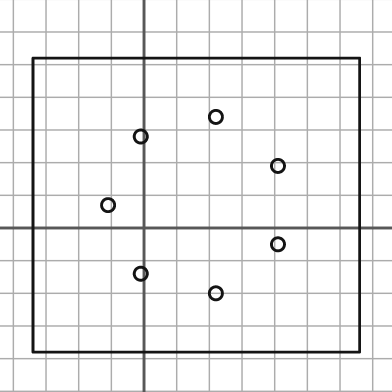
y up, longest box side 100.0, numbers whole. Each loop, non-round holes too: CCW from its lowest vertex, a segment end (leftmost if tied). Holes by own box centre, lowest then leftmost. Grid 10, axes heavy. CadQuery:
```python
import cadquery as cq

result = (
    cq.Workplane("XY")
    .moveTo(-34.0, -38.0)
    .lineTo(66.0, -38.0)
    .lineTo(66.0, 52.0)
    .lineTo(-34.0, 52.0)
    .close()
    .moveTo(22.0, -20.0)
    .circle(2.0)
    .moveTo(-1.0, -14.0)
    .circle(2.0)
    .moveTo(41.0, -5.0)
    .circle(2.0)
    .moveTo(-11.0, 7.0)
    .circle(2.0)
    .moveTo(41.0, 19.0)
    .circle(2.0)
    .moveTo(-1.0, 28.0)
    .circle(2.0)
    .moveTo(22.0, 34.0)
    .circle(2.0)
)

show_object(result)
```